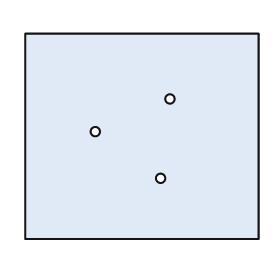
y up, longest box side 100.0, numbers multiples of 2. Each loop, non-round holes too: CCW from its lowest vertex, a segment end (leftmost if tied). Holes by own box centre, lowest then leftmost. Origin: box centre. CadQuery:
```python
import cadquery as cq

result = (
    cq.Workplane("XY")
    .moveTo(-50.0, -44.0)
    .lineTo(50.0, -44.0)
    .lineTo(50.0, 44.0)
    .lineTo(-50.0, 44.0)
    .close()
    .moveTo(8.0, -18.0)
    .circle(2.0)
    .moveTo(-20.0, 2.0)
    .circle(2.0)
    .moveTo(12.0, 16.0)
    .circle(2.0)
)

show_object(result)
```